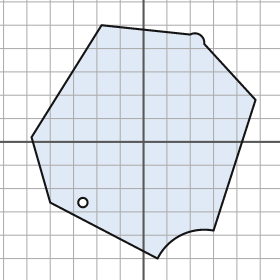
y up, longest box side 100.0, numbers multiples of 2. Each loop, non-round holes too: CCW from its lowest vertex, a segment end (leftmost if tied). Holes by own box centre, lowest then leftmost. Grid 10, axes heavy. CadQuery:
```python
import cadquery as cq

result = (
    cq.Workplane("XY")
    .moveTo(6.0, -50.0)
    .threePointArc((16.0, -40.0), (30.0, -38.0))
    .lineTo(48.0, 18.0)
    .lineTo(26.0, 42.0)
    .threePointArc((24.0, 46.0), (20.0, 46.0))
    .lineTo(-18.0, 50.0)
    .lineTo(-48.0, 2.0)
    .lineTo(-40.0, -26.0)
    .close()
    .moveTo(-26.0, -26.0)
    .circle(2.0)
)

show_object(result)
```